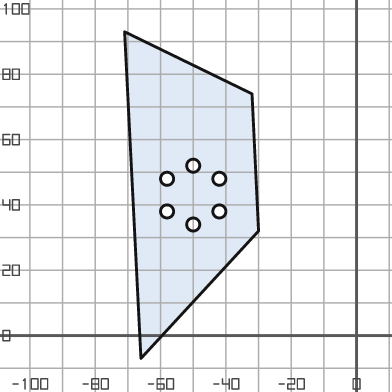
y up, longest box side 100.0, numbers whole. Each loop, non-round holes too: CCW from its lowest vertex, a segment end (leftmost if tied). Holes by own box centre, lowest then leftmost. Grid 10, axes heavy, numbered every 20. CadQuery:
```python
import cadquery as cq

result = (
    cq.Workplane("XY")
    .moveTo(-66.0, -7.0)
    .lineTo(-30.0, 32.0)
    .lineTo(-32.0, 74.0)
    .lineTo(-71.0, 93.0)
    .close()
    .moveTo(-50.0, 34.0)
    .circle(2.0)
    .moveTo(-58.0, 38.0)
    .circle(2.0)
    .moveTo(-42.0, 38.0)
    .circle(2.0)
    .moveTo(-58.0, 48.0)
    .circle(2.0)
    .moveTo(-42.0, 48.0)
    .circle(2.0)
    .moveTo(-50.0, 52.0)
    .circle(2.0)
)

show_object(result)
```